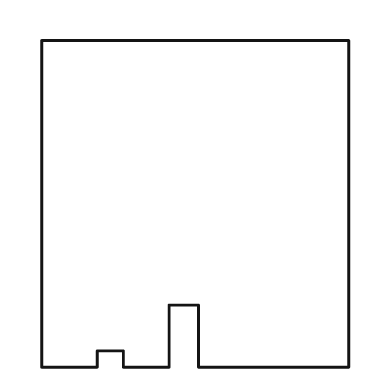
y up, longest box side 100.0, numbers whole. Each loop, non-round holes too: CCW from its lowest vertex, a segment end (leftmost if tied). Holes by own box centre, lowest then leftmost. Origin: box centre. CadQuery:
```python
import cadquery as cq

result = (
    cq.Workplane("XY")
    .moveTo(-47.0, -50.0)
    .lineTo(-30.0, -50.0)
    .lineTo(-30.0, -45.0)
    .lineTo(-22.0, -45.0)
    .lineTo(-22.0, -50.0)
    .lineTo(-8.0, -50.0)
    .lineTo(-8.0, -31.0)
    .lineTo(1.0, -31.0)
    .lineTo(1.0, -50.0)
    .lineTo(47.0, -50.0)
    .lineTo(47.0, 50.0)
    .lineTo(-47.0, 50.0)
    .close()
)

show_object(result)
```